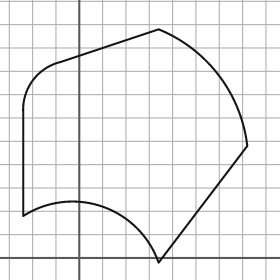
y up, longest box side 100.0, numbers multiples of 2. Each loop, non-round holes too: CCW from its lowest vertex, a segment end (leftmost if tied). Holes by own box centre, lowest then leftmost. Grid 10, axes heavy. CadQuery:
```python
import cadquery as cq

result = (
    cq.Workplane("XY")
    .moveTo(34.0, -2.0)
    .lineTo(72.0, 48.0)
    .threePointArc((60.0, 78.0), (34.0, 98.0))
    .lineTo(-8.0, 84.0)
    .threePointArc((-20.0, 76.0), (-24.0, 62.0))
    .lineTo(-24.0, 18.0)
    .threePointArc((10.0, 22.0), (34.0, -2.0))
    .close()
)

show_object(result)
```